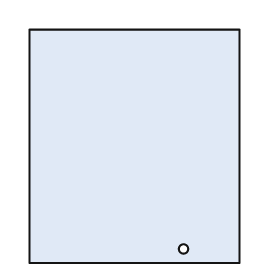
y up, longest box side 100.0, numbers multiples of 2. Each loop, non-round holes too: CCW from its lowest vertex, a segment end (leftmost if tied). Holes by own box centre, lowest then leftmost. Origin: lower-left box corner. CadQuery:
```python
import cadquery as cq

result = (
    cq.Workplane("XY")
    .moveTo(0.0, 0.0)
    .lineTo(90.0, 0.0)
    .lineTo(90.0, 100.0)
    .lineTo(0.0, 100.0)
    .close()
    .moveTo(66.0, 6.0)
    .circle(2.0)
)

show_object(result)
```